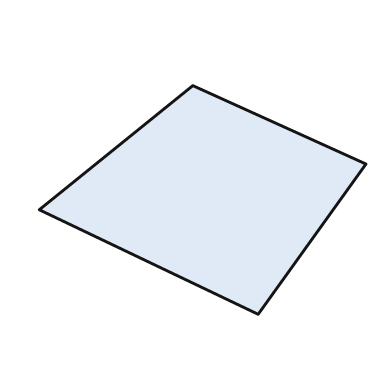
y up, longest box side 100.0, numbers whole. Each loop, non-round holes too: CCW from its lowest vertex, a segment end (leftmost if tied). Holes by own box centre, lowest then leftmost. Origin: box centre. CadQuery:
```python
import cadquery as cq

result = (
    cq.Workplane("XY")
    .moveTo(17.0, -35.0)
    .lineTo(50.0, 11.0)
    .lineTo(-3.0, 35.0)
    .lineTo(-50.0, -3.0)
    .close()
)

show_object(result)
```